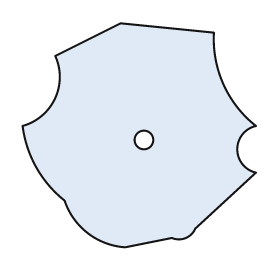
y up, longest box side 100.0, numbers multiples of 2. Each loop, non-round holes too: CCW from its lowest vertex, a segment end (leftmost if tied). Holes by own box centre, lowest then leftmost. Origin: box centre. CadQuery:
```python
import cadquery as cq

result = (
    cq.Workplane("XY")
    .moveTo(-6.0, -48.0)
    .lineTo(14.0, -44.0)
    .threePointArc((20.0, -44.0), (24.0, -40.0))
    .lineTo(50.0, -16.0)
    .threePointArc((42.0, -6.0), (50.0, 4.0))
    .threePointArc((36.0, 22.0), (32.0, 44.0))
    .lineTo(-8.0, 48.0)
    .lineTo(-36.0, 34.0)
    .threePointArc((-36.0, 16.0), (-50.0, 4.0))
    .threePointArc((-44.0, -14.0), (-32.0, -28.0))
    .threePointArc((-22.0, -42.0), (-6.0, -48.0))
    .close()
    .moveTo(2.0, -2.0)
    .circle(4.0)
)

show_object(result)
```